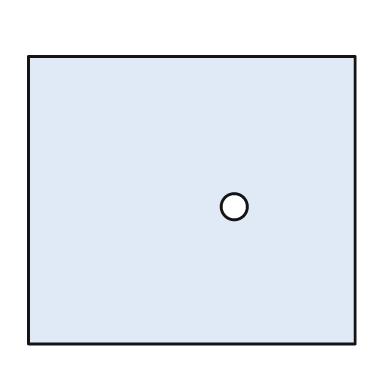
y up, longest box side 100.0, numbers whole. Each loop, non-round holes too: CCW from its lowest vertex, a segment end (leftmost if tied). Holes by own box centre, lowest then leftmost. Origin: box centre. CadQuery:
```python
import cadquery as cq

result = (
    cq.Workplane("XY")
    .moveTo(-50.0, -44.0)
    .lineTo(50.0, -44.0)
    .lineTo(50.0, 44.0)
    .lineTo(-50.0, 44.0)
    .close()
    .moveTo(13.0, -2.0)
    .circle(4.0)
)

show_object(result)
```